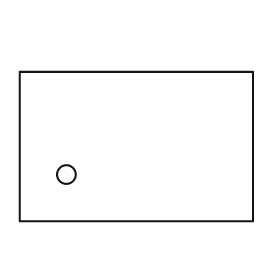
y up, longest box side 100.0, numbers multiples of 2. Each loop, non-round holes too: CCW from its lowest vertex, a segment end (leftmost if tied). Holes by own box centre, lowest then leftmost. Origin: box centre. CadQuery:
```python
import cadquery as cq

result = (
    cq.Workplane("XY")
    .moveTo(-50.0, -32.0)
    .lineTo(50.0, -32.0)
    .lineTo(50.0, 32.0)
    .lineTo(-50.0, 32.0)
    .close()
    .moveTo(-30.0, -12.0)
    .circle(4.0)
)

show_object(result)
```